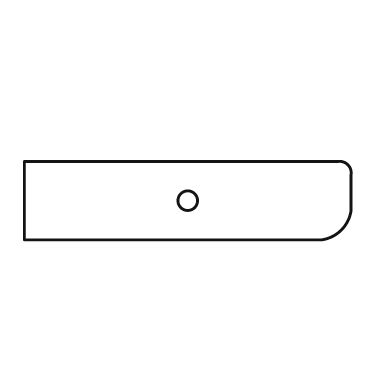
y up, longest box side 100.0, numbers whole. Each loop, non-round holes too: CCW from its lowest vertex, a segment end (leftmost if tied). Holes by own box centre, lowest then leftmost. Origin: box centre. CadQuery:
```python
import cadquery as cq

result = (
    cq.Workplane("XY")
    .moveTo(-50.0, -12.0)
    .lineTo(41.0, -12.0)
    .threePointArc((47.0, -9.0), (50.0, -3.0))
    .lineTo(50.0, 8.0)
    .threePointArc((49.0, 11.0), (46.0, 12.0))
    .lineTo(-50.0, 12.0)
    .close()
    .moveTo(0.0, 0.0)
    .circle(3.0)
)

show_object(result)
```